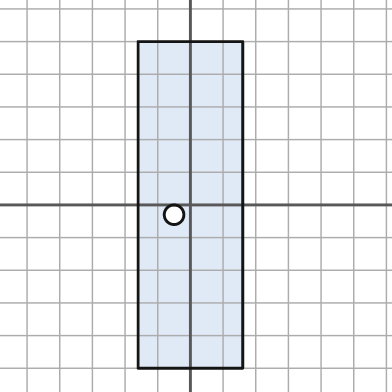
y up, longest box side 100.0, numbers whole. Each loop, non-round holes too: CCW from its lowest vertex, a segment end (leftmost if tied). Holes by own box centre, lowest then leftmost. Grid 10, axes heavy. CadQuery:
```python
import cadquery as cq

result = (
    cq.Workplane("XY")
    .moveTo(-16.0, -50.0)
    .lineTo(16.0, -50.0)
    .lineTo(16.0, 50.0)
    .lineTo(-16.0, 50.0)
    .close()
    .moveTo(-5.0, -3.0)
    .circle(3.0)
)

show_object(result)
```